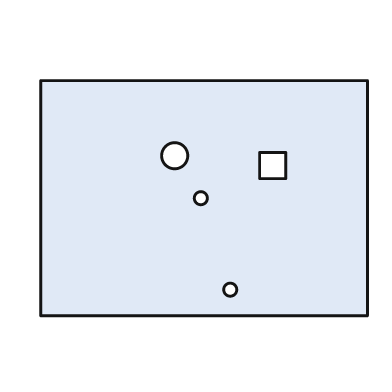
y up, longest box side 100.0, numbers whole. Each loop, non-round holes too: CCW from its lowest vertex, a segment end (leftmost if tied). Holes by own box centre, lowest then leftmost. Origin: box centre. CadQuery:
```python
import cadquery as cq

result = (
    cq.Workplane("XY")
    .moveTo(-50.0, -36.0)
    .lineTo(50.0, -36.0)
    .lineTo(50.0, 36.0)
    .lineTo(-50.0, 36.0)
    .close()
    .moveTo(8.0, -28.0)
    .circle(2.0)
    .moveTo(-1.0, 0.0)
    .circle(2.0)
    .moveTo(17.0, 6.0)
    .lineTo(25.0, 6.0)
    .lineTo(25.0, 14.0)
    .lineTo(17.0, 14.0)
    .close()
    .moveTo(-9.0, 13.0)
    .circle(4.0)
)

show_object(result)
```